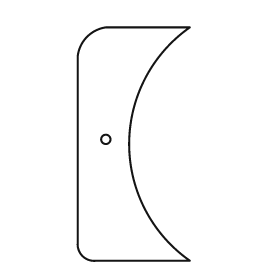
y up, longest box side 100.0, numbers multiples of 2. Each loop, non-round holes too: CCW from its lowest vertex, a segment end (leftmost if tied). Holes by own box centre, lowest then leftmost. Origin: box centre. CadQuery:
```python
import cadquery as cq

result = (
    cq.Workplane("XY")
    .moveTo(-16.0, -50.0)
    .lineTo(24.0, -50.0)
    .threePointArc((-2.0, 0.0), (24.0, 50.0))
    .lineTo(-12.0, 50.0)
    .threePointArc((-20.0, 46.0), (-24.0, 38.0))
    .lineTo(-24.0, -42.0)
    .threePointArc((-22.0, -48.0), (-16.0, -50.0))
    .close()
    .moveTo(-12.0, 2.0)
    .circle(2.0)
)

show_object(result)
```